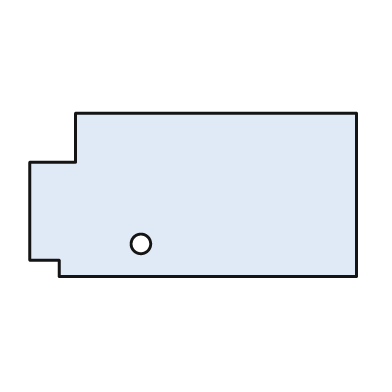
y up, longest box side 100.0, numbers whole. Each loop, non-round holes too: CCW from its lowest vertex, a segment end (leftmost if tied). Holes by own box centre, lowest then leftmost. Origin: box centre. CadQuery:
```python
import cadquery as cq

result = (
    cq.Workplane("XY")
    .moveTo(-41.0, -25.0)
    .lineTo(50.0, -25.0)
    .lineTo(50.0, 25.0)
    .lineTo(-36.0, 25.0)
    .lineTo(-36.0, 10.0)
    .lineTo(-50.0, 10.0)
    .lineTo(-50.0, -20.0)
    .lineTo(-41.0, -20.0)
    .close()
    .moveTo(-16.0, -15.0)
    .circle(3.0)
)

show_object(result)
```